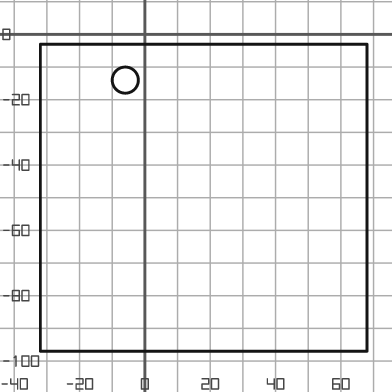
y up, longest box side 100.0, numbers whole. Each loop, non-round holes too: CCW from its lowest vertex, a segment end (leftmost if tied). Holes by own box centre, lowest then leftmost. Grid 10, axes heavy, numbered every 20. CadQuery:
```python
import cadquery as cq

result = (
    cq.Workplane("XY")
    .moveTo(-32.0, -97.0)
    .lineTo(68.0, -97.0)
    .lineTo(68.0, -3.0)
    .lineTo(-32.0, -3.0)
    .close()
    .moveTo(-6.0, -14.0)
    .circle(4.0)
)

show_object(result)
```